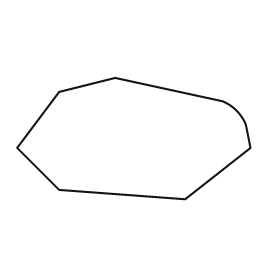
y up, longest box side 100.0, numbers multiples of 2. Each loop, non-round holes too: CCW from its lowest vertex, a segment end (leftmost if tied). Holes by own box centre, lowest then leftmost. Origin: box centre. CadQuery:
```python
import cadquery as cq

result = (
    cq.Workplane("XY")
    .moveTo(22.0, -26.0)
    .lineTo(50.0, -4.0)
    .lineTo(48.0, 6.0)
    .threePointArc((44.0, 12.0), (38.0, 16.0))
    .lineTo(-8.0, 26.0)
    .lineTo(-32.0, 20.0)
    .lineTo(-50.0, -4.0)
    .lineTo(-32.0, -22.0)
    .close()
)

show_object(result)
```